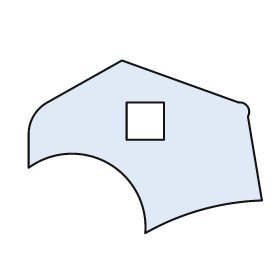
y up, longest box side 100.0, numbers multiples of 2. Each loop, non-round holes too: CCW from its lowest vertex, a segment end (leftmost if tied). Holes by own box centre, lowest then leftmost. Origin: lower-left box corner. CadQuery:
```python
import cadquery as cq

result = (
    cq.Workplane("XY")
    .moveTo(50.0, 0.0)
    .threePointArc((74.0, 10.0), (100.0, 14.0))
    .lineTo(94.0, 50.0)
    .threePointArc((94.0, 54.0), (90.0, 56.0))
    .lineTo(40.0, 74.0)
    .lineTo(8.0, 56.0)
    .threePointArc((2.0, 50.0), (0.0, 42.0))
    .lineTo(0.0, 28.0)
    .threePointArc((34.0, 30.0), (50.0, 0.0))
    .close()
    .moveTo(42.0, 40.0)
    .lineTo(58.0, 40.0)
    .lineTo(58.0, 56.0)
    .lineTo(42.0, 56.0)
    .close()
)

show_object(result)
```